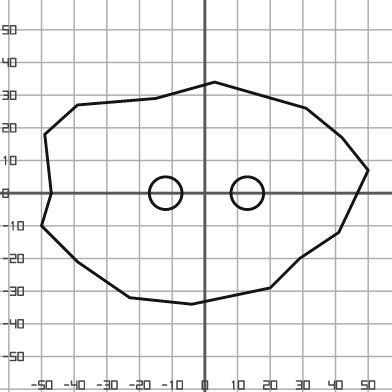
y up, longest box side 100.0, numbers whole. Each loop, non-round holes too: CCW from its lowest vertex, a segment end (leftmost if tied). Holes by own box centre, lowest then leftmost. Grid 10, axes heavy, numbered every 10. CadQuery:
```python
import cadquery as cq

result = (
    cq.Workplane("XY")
    .moveTo(-4.0, -34.0)
    .lineTo(20.0, -29.0)
    .lineTo(29.0, -20.0)
    .lineTo(41.0, -12.0)
    .lineTo(50.0, 7.0)
    .lineTo(42.0, 17.0)
    .lineTo(31.0, 26.0)
    .lineTo(3.0, 34.0)
    .lineTo(-15.0, 29.0)
    .lineTo(-39.0, 27.0)
    .lineTo(-49.0, 18.0)
    .lineTo(-47.0, 0.0)
    .lineTo(-50.0, -10.0)
    .lineTo(-39.0, -21.0)
    .lineTo(-23.0, -32.0)
    .close()
    .moveTo(-12.0, 0.0)
    .circle(5.0)
    .moveTo(13.0, 0.0)
    .circle(5.0)
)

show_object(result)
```